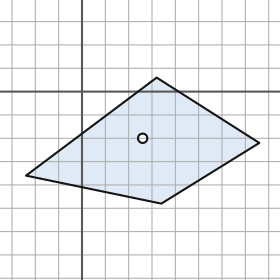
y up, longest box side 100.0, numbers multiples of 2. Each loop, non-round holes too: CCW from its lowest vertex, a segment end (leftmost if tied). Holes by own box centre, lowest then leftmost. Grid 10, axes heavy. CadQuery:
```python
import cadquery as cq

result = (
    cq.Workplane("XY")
    .moveTo(34.0, -48.0)
    .lineTo(76.0, -22.0)
    .lineTo(32.0, 6.0)
    .lineTo(-24.0, -36.0)
    .close()
    .moveTo(26.0, -20.0)
    .circle(2.0)
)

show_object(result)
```